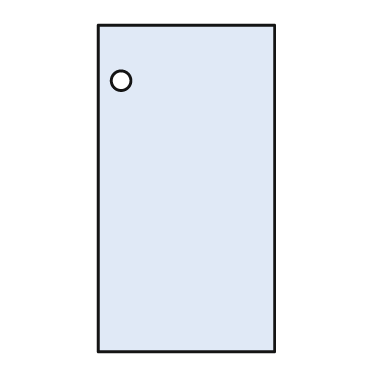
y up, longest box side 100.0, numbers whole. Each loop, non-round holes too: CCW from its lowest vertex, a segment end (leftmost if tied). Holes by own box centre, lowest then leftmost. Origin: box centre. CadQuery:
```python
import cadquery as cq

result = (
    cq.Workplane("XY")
    .moveTo(-27.0, -50.0)
    .lineTo(27.0, -50.0)
    .lineTo(27.0, 50.0)
    .lineTo(-27.0, 50.0)
    .close()
    .moveTo(-20.0, 33.0)
    .circle(3.0)
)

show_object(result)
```